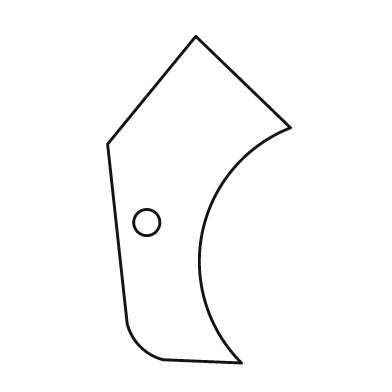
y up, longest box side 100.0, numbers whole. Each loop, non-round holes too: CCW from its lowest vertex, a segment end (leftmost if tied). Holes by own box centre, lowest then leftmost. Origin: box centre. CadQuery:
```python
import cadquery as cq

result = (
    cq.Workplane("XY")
    .moveTo(13.0, -50.0)
    .threePointArc((1.0, -10.0), (28.0, 22.0))
    .lineTo(-1.0, 50.0)
    .lineTo(-28.0, 17.0)
    .lineTo(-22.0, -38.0)
    .threePointArc((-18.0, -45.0), (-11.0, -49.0))
    .close()
    .moveTo(-16.0, -7.0)
    .circle(4.0)
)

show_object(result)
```